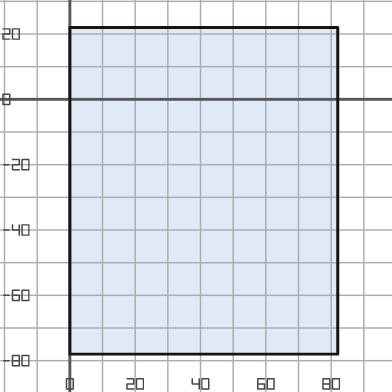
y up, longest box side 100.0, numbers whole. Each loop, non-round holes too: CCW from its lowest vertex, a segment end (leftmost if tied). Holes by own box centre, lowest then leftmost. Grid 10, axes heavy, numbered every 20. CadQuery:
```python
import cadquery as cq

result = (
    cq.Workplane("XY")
    .moveTo(0.0, -78.0)
    .lineTo(82.0, -78.0)
    .lineTo(82.0, 22.0)
    .lineTo(0.0, 22.0)
    .close()
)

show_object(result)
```